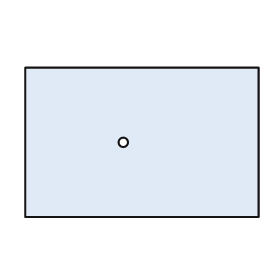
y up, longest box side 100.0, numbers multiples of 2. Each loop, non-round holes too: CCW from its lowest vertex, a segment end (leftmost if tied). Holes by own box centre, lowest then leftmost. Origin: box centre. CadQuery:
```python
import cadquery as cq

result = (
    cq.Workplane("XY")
    .moveTo(-50.0, -32.0)
    .lineTo(50.0, -32.0)
    .lineTo(50.0, 32.0)
    .lineTo(-50.0, 32.0)
    .close()
    .moveTo(-8.0, 0.0)
    .circle(2.0)
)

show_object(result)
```